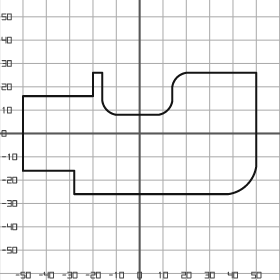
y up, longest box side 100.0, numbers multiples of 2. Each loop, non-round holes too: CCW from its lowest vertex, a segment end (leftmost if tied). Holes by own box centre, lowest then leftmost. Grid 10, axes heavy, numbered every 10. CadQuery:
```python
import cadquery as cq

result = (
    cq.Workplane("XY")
    .moveTo(-28.0, -26.0)
    .lineTo(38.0, -26.0)
    .threePointArc((46.0, -22.0), (50.0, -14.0))
    .lineTo(50.0, 26.0)
    .lineTo(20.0, 26.0)
    .threePointArc((16.0, 24.0), (14.0, 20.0))
    .lineTo(14.0, 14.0)
    .threePointArc((12.0, 10.0), (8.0, 8.0))
    .lineTo(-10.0, 8.0)
    .threePointArc((-14.0, 10.0), (-16.0, 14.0))
    .lineTo(-16.0, 26.0)
    .lineTo(-20.0, 26.0)
    .lineTo(-20.0, 16.0)
    .lineTo(-50.0, 16.0)
    .lineTo(-50.0, -16.0)
    .lineTo(-28.0, -16.0)
    .close()
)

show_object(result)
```